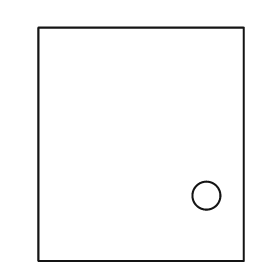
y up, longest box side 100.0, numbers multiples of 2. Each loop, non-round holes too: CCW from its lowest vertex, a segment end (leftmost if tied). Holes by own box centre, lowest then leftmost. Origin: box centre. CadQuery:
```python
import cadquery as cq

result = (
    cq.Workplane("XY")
    .moveTo(-44.0, -50.0)
    .lineTo(44.0, -50.0)
    .lineTo(44.0, 50.0)
    .lineTo(-44.0, 50.0)
    .close()
    .moveTo(28.0, -22.0)
    .circle(6.0)
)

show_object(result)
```